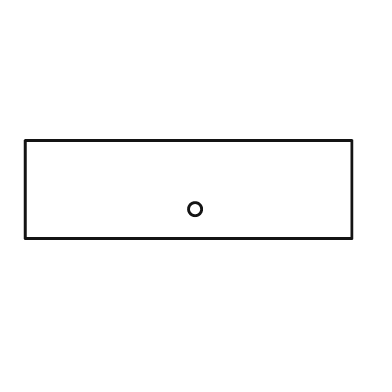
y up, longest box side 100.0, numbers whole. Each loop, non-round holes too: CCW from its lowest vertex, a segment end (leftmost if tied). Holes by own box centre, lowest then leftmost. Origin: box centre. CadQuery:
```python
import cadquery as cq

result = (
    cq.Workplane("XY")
    .moveTo(-50.0, -15.0)
    .lineTo(50.0, -15.0)
    .lineTo(50.0, 15.0)
    .lineTo(-50.0, 15.0)
    .close()
    .moveTo(2.0, -6.0)
    .circle(2.0)
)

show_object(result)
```